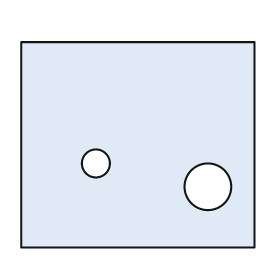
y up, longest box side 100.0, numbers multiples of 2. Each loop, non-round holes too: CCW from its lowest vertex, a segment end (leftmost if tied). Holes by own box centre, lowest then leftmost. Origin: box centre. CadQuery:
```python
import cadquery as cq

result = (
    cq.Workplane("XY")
    .moveTo(-50.0, -44.0)
    .lineTo(50.0, -44.0)
    .lineTo(50.0, 44.0)
    .lineTo(-50.0, 44.0)
    .close()
    .moveTo(30.0, -18.0)
    .circle(10.0)
    .moveTo(-18.0, -8.0)
    .circle(6.0)
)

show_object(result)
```